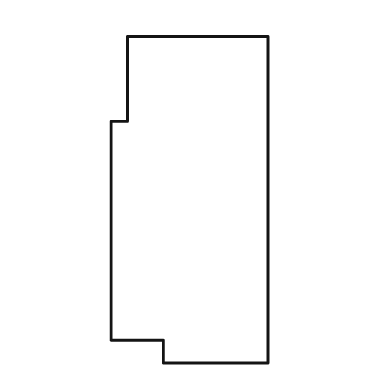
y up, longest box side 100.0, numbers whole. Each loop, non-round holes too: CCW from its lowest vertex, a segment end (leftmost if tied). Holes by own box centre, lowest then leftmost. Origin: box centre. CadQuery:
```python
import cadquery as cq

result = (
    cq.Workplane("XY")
    .moveTo(-8.0, -50.0)
    .lineTo(24.0, -50.0)
    .lineTo(24.0, 50.0)
    .lineTo(-19.0, 50.0)
    .lineTo(-19.0, 24.0)
    .lineTo(-24.0, 24.0)
    .lineTo(-24.0, -43.0)
    .lineTo(-8.0, -43.0)
    .close()
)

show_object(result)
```